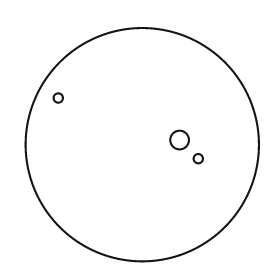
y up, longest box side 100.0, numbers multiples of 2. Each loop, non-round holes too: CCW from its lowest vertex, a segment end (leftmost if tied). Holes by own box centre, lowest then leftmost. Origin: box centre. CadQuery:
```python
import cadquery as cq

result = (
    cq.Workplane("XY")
    .moveTo(0.0, 0.0)
    .circle(50.0)
    .moveTo(24.0, -6.0)
    .circle(2.0)
    .moveTo(16.0, 2.0)
    .circle(4.0)
    .moveTo(-36.0, 20.0)
    .circle(2.0)
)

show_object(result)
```